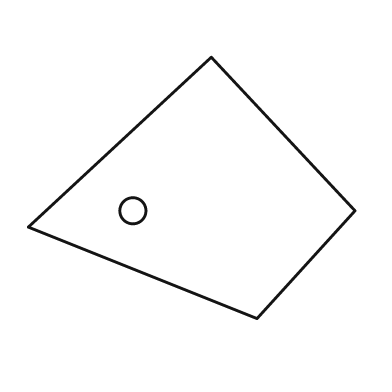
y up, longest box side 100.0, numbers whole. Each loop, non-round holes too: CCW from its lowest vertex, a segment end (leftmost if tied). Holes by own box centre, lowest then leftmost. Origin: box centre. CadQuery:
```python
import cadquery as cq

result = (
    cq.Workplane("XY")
    .moveTo(20.0, -40.0)
    .lineTo(50.0, -7.0)
    .lineTo(6.0, 40.0)
    .lineTo(-50.0, -12.0)
    .close()
    .moveTo(-18.0, -7.0)
    .circle(4.0)
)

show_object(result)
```